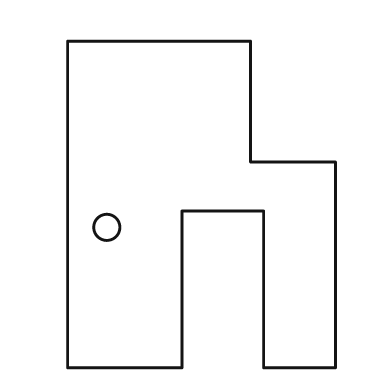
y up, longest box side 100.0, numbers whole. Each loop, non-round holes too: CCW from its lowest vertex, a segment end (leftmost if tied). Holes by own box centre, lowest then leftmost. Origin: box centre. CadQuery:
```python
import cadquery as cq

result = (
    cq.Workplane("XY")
    .moveTo(-41.0, -50.0)
    .lineTo(-6.0, -50.0)
    .lineTo(-6.0, -2.0)
    .lineTo(19.0, -2.0)
    .lineTo(19.0, -50.0)
    .lineTo(41.0, -50.0)
    .lineTo(41.0, 13.0)
    .lineTo(15.0, 13.0)
    .lineTo(15.0, 50.0)
    .lineTo(-41.0, 50.0)
    .close()
    .moveTo(-29.0, -7.0)
    .circle(4.0)
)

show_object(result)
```